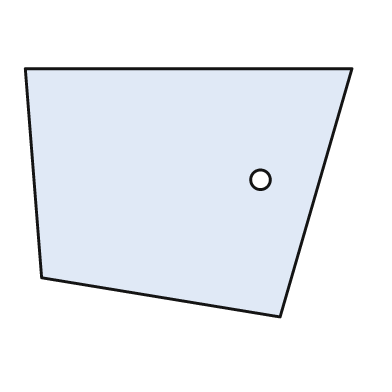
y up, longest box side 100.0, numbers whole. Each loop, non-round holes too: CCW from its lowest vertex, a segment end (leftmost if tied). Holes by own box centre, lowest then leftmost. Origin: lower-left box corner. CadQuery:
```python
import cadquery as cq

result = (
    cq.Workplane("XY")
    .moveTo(78.0, 0.0)
    .lineTo(100.0, 76.0)
    .lineTo(0.0, 76.0)
    .lineTo(5.0, 12.0)
    .close()
    .moveTo(72.0, 42.0)
    .circle(3.0)
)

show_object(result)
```